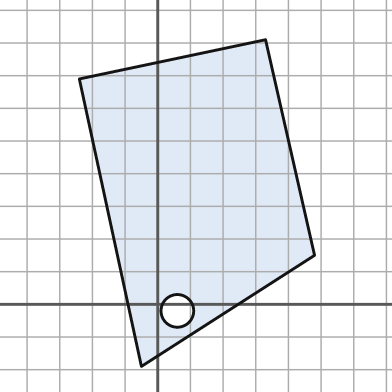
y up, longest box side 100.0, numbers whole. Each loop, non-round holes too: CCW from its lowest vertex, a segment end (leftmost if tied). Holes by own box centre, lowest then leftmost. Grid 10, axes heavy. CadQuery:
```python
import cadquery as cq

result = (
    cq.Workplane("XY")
    .moveTo(-5.0, -19.0)
    .lineTo(48.0, 15.0)
    .lineTo(33.0, 81.0)
    .lineTo(-24.0, 69.0)
    .close()
    .moveTo(6.0, -2.0)
    .circle(5.0)
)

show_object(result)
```